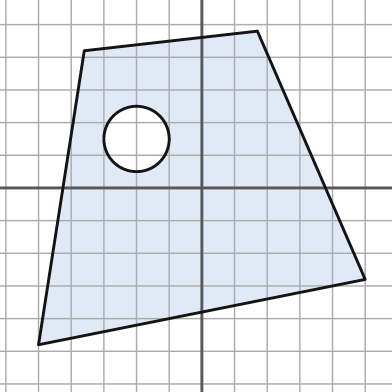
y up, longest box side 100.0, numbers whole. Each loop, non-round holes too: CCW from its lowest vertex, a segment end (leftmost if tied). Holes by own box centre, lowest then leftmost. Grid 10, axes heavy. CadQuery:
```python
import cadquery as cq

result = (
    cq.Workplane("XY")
    .moveTo(-50.0, -48.0)
    .lineTo(50.0, -28.0)
    .lineTo(17.0, 48.0)
    .lineTo(-36.0, 42.0)
    .close()
    .moveTo(-20.0, 15.0)
    .circle(10.0)
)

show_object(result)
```